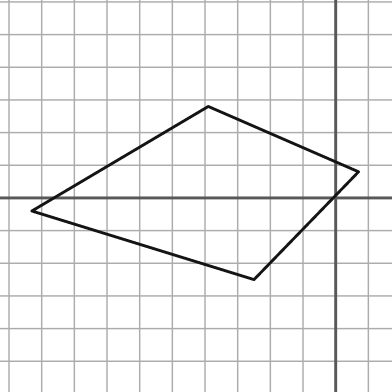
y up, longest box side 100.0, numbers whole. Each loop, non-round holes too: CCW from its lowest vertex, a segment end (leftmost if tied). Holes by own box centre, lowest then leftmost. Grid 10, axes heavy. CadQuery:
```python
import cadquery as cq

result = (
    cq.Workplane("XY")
    .moveTo(-25.0, -25.0)
    .lineTo(7.0, 8.0)
    .lineTo(-39.0, 28.0)
    .lineTo(-93.0, -4.0)
    .close()
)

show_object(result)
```